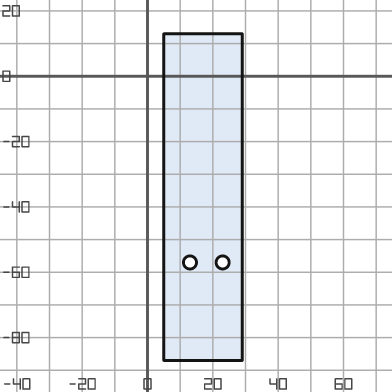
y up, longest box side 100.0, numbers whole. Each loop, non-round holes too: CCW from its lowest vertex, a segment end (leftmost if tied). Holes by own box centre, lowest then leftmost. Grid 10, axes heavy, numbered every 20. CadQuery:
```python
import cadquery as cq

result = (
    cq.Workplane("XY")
    .moveTo(5.0, -87.0)
    .lineTo(29.0, -87.0)
    .lineTo(29.0, 13.0)
    .lineTo(5.0, 13.0)
    .close()
    .moveTo(13.0, -57.0)
    .circle(2.0)
    .moveTo(23.0, -57.0)
    .circle(2.0)
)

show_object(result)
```